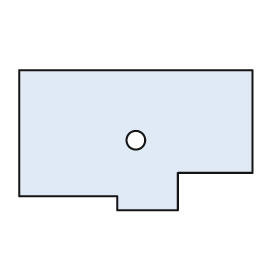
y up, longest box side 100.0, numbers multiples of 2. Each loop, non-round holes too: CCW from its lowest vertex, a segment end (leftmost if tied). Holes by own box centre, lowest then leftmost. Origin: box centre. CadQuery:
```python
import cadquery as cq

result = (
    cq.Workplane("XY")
    .moveTo(-8.0, -30.0)
    .lineTo(18.0, -30.0)
    .lineTo(18.0, -14.0)
    .lineTo(50.0, -14.0)
    .lineTo(50.0, 30.0)
    .lineTo(-50.0, 30.0)
    .lineTo(-50.0, -24.0)
    .lineTo(-8.0, -24.0)
    .close()
    .moveTo(0.0, 0.0)
    .circle(4.0)
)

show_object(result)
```